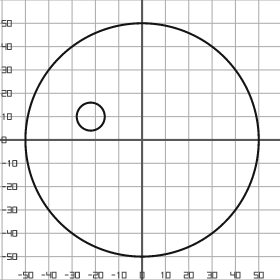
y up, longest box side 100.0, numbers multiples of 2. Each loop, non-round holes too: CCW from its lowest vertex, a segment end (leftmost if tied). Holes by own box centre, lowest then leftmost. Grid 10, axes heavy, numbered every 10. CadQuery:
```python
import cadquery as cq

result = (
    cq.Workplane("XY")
    .moveTo(0.0, 0.0)
    .circle(50.0)
    .moveTo(-22.0, 10.0)
    .circle(6.0)
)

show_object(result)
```